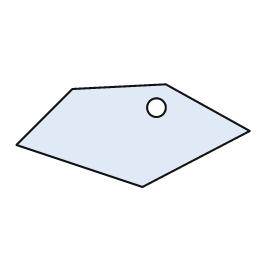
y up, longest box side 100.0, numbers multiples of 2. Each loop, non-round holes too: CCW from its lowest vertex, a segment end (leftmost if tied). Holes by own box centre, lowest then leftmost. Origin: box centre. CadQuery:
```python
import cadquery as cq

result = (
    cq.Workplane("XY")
    .moveTo(4.0, -22.0)
    .lineTo(50.0, 2.0)
    .lineTo(14.0, 22.0)
    .lineTo(-26.0, 20.0)
    .lineTo(-50.0, -4.0)
    .close()
    .moveTo(10.0, 12.0)
    .circle(4.0)
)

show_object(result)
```